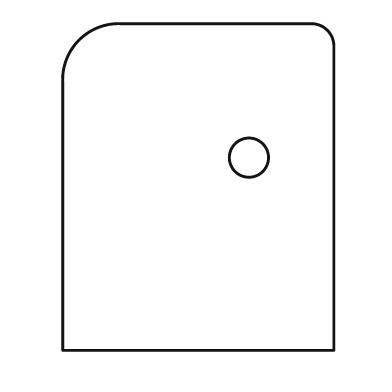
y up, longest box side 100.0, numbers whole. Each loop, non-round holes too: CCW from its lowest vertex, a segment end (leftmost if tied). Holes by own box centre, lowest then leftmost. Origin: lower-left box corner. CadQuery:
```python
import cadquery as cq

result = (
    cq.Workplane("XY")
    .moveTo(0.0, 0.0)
    .lineTo(83.0, 0.0)
    .lineTo(83.0, 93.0)
    .threePointArc((81.0, 98.0), (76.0, 100.0))
    .lineTo(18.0, 100.0)
    .threePointArc((5.0, 95.0), (0.0, 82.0))
    .close()
    .moveTo(57.0, 59.0)
    .circle(6.0)
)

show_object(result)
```